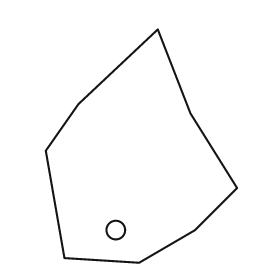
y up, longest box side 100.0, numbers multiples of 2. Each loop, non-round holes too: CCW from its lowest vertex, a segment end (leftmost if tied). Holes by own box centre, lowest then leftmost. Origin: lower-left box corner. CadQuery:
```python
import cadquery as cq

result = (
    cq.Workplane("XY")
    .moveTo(40.0, 0.0)
    .lineTo(64.0, 14.0)
    .lineTo(82.0, 32.0)
    .lineTo(62.0, 64.0)
    .lineTo(48.0, 100.0)
    .lineTo(14.0, 68.0)
    .lineTo(0.0, 48.0)
    .lineTo(8.0, 2.0)
    .close()
    .moveTo(30.0, 14.0)
    .circle(4.0)
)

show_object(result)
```